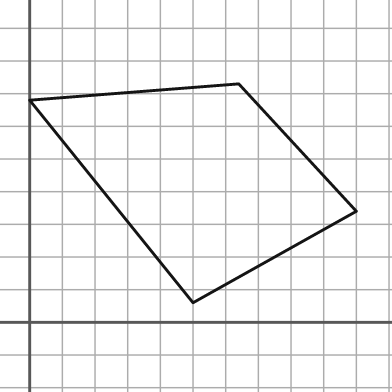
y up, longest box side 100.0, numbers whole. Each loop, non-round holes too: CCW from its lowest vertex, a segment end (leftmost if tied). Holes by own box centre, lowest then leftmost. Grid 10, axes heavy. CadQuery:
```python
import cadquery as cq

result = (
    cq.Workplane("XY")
    .moveTo(50.0, 6.0)
    .lineTo(100.0, 34.0)
    .lineTo(64.0, 73.0)
    .lineTo(0.0, 68.0)
    .close()
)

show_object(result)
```